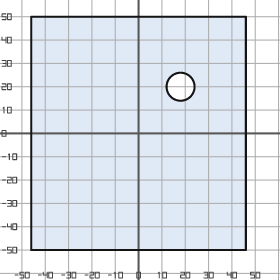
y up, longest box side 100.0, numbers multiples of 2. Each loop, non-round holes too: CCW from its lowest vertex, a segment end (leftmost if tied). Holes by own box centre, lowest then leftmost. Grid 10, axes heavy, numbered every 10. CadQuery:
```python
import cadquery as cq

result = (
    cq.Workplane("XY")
    .moveTo(-46.0, -50.0)
    .lineTo(46.0, -50.0)
    .lineTo(46.0, 50.0)
    .lineTo(-46.0, 50.0)
    .close()
    .moveTo(18.0, 20.0)
    .circle(6.0)
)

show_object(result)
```